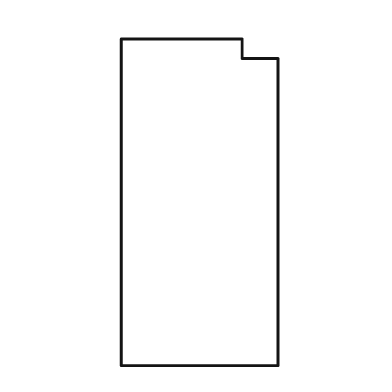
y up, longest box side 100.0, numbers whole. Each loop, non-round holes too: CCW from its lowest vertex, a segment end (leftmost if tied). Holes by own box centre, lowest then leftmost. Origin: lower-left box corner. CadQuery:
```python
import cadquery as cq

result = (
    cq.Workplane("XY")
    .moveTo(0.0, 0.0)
    .lineTo(48.0, 0.0)
    .lineTo(48.0, 94.0)
    .lineTo(37.0, 94.0)
    .lineTo(37.0, 100.0)
    .lineTo(0.0, 100.0)
    .close()
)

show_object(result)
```